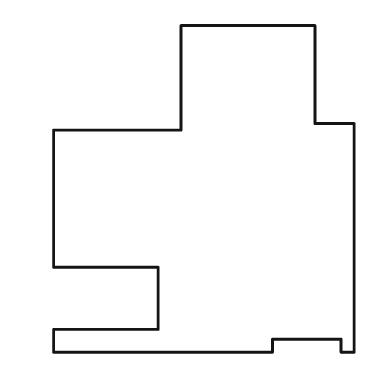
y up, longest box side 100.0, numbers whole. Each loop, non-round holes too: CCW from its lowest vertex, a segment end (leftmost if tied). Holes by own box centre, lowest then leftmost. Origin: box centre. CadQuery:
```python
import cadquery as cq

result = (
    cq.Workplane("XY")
    .moveTo(-46.0, -50.0)
    .lineTo(21.0, -50.0)
    .lineTo(21.0, -46.0)
    .lineTo(42.0, -46.0)
    .lineTo(42.0, -50.0)
    .lineTo(46.0, -50.0)
    .lineTo(46.0, 20.0)
    .lineTo(34.0, 20.0)
    .lineTo(34.0, 50.0)
    .lineTo(-7.0, 50.0)
    .lineTo(-7.0, 18.0)
    .lineTo(-46.0, 18.0)
    .lineTo(-46.0, -24.0)
    .lineTo(-14.0, -24.0)
    .lineTo(-14.0, -43.0)
    .lineTo(-46.0, -43.0)
    .close()
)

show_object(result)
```